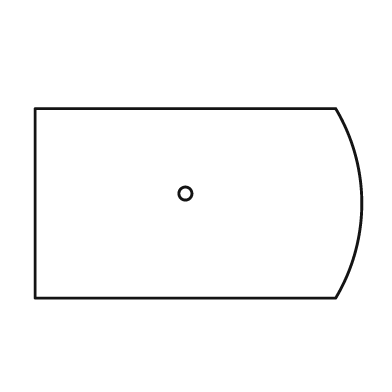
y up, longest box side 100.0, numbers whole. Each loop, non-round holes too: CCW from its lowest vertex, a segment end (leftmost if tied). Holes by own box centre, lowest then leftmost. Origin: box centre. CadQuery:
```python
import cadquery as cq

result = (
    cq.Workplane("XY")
    .moveTo(-50.0, -29.0)
    .lineTo(42.0, -29.0)
    .threePointArc((50.0, 0.0), (42.0, 29.0))
    .lineTo(-50.0, 29.0)
    .close()
    .moveTo(-4.0, 3.0)
    .circle(2.0)
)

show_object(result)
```